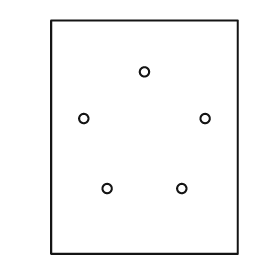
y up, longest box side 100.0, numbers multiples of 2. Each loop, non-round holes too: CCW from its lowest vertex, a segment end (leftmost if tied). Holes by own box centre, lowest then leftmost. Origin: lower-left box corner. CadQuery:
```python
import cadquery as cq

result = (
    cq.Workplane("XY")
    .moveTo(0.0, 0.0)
    .lineTo(80.0, 0.0)
    .lineTo(80.0, 100.0)
    .lineTo(0.0, 100.0)
    .close()
    .moveTo(24.0, 28.0)
    .circle(2.0)
    .moveTo(56.0, 28.0)
    .circle(2.0)
    .moveTo(14.0, 58.0)
    .circle(2.0)
    .moveTo(66.0, 58.0)
    .circle(2.0)
    .moveTo(40.0, 78.0)
    .circle(2.0)
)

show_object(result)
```